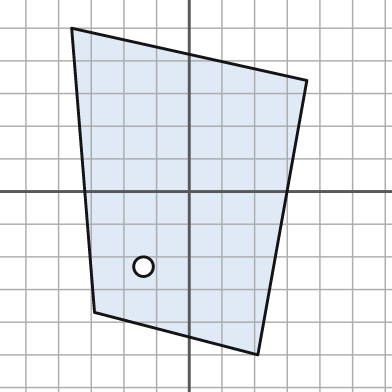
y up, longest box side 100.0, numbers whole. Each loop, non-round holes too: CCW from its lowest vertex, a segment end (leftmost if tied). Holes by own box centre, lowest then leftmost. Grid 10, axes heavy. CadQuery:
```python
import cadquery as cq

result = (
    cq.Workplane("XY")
    .moveTo(21.0, -50.0)
    .lineTo(36.0, 34.0)
    .lineTo(-36.0, 50.0)
    .lineTo(-29.0, -37.0)
    .close()
    .moveTo(-14.0, -23.0)
    .circle(3.0)
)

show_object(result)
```